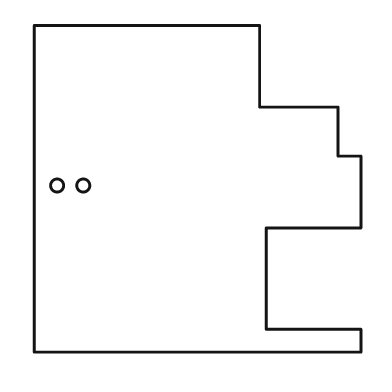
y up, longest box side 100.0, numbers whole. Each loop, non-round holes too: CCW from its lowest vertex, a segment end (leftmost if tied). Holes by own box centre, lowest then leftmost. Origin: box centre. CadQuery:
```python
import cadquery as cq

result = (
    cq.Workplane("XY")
    .moveTo(-50.0, -50.0)
    .lineTo(50.0, -50.0)
    .lineTo(50.0, -43.0)
    .lineTo(21.0, -43.0)
    .lineTo(21.0, -12.0)
    .lineTo(50.0, -12.0)
    .lineTo(50.0, 10.0)
    .lineTo(43.0, 10.0)
    .lineTo(43.0, 25.0)
    .lineTo(19.0, 25.0)
    .lineTo(19.0, 50.0)
    .lineTo(-50.0, 50.0)
    .close()
    .moveTo(-43.0, 1.0)
    .circle(2.0)
    .moveTo(-35.0, 1.0)
    .circle(2.0)
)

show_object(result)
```